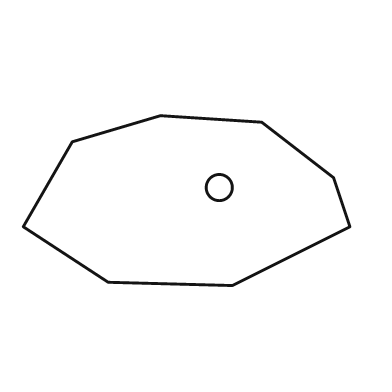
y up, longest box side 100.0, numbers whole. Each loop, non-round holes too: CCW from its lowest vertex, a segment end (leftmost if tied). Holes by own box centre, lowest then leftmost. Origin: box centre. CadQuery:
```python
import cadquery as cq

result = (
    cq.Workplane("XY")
    .moveTo(14.0, -26.0)
    .lineTo(50.0, -8.0)
    .lineTo(45.0, 7.0)
    .lineTo(23.0, 24.0)
    .lineTo(-8.0, 26.0)
    .lineTo(-35.0, 18.0)
    .lineTo(-50.0, -8.0)
    .lineTo(-24.0, -25.0)
    .close()
    .moveTo(10.0, 4.0)
    .circle(4.0)
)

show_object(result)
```